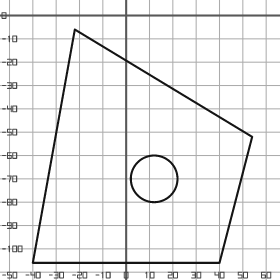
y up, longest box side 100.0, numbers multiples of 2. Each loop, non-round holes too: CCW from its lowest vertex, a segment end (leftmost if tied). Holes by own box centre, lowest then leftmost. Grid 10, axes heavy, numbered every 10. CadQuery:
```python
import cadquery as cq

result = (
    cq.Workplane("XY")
    .moveTo(-40.0, -106.0)
    .lineTo(40.0, -106.0)
    .lineTo(54.0, -52.0)
    .lineTo(-22.0, -6.0)
    .close()
    .moveTo(12.0, -70.0)
    .circle(10.0)
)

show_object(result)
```